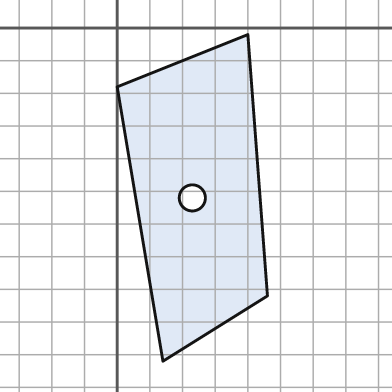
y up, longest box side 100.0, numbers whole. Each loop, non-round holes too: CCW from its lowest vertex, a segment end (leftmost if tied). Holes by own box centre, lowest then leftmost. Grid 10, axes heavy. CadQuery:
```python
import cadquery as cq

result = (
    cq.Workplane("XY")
    .moveTo(14.0, -102.0)
    .lineTo(46.0, -82.0)
    .lineTo(40.0, -2.0)
    .lineTo(0.0, -18.0)
    .close()
    .moveTo(23.0, -52.0)
    .circle(4.0)
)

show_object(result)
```